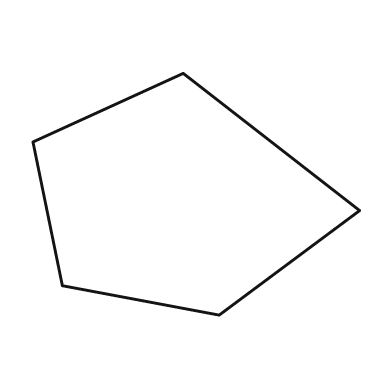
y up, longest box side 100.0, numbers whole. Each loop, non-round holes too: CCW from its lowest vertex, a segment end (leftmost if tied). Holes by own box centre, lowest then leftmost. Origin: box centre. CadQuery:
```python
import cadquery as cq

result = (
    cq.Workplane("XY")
    .moveTo(7.0, -37.0)
    .lineTo(50.0, -5.0)
    .lineTo(-4.0, 37.0)
    .lineTo(-50.0, 16.0)
    .lineTo(-41.0, -28.0)
    .close()
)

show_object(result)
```